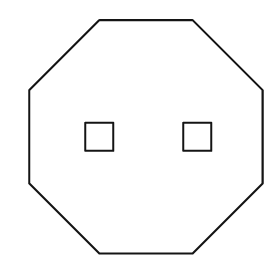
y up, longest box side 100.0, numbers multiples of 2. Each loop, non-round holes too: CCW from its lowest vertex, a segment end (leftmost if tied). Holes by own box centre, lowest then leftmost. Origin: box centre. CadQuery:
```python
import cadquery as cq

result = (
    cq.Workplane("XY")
    .moveTo(-20.0, -50.0)
    .lineTo(20.0, -50.0)
    .lineTo(50.0, -20.0)
    .lineTo(50.0, 20.0)
    .lineTo(20.0, 50.0)
    .lineTo(-20.0, 50.0)
    .lineTo(-50.0, 20.0)
    .lineTo(-50.0, -20.0)
    .close()
    .moveTo(-26.0, -6.0)
    .lineTo(-14.0, -6.0)
    .lineTo(-14.0, 6.0)
    .lineTo(-26.0, 6.0)
    .close()
    .moveTo(16.0, -6.0)
    .lineTo(28.0, -6.0)
    .lineTo(28.0, 6.0)
    .lineTo(16.0, 6.0)
    .close()
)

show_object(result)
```